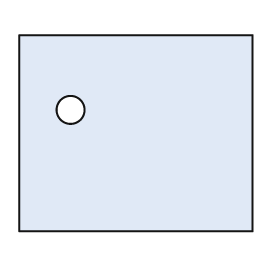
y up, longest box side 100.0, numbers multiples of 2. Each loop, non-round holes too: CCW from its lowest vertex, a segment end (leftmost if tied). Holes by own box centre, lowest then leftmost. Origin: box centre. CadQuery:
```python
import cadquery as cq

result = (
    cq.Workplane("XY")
    .moveTo(-50.0, -42.0)
    .lineTo(50.0, -42.0)
    .lineTo(50.0, 42.0)
    .lineTo(-50.0, 42.0)
    .close()
    .moveTo(-28.0, 10.0)
    .circle(6.0)
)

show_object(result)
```